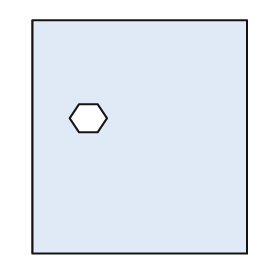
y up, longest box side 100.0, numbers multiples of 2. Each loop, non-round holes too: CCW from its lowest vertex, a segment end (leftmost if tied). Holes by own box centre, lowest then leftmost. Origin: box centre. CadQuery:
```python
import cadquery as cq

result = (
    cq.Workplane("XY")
    .moveTo(-46.0, -50.0)
    .lineTo(46.0, -50.0)
    .lineTo(46.0, 50.0)
    .lineTo(-46.0, 50.0)
    .close()
    .moveTo(-26.0, 2.0)
    .lineTo(-18.0, 2.0)
    .lineTo(-14.0, 8.0)
    .lineTo(-18.0, 14.0)
    .lineTo(-26.0, 14.0)
    .lineTo(-30.0, 8.0)
    .close()
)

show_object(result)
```